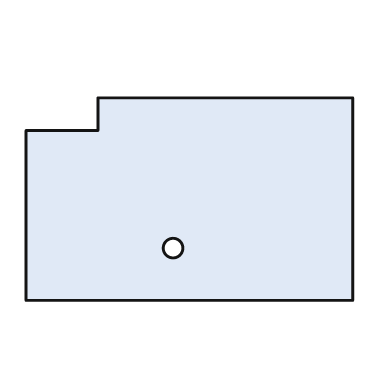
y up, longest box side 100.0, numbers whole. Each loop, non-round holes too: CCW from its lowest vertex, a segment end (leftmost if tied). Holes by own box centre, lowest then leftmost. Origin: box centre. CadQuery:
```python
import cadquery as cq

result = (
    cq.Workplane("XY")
    .moveTo(-50.0, -31.0)
    .lineTo(50.0, -31.0)
    .lineTo(50.0, 31.0)
    .lineTo(-28.0, 31.0)
    .lineTo(-28.0, 21.0)
    .lineTo(-50.0, 21.0)
    .close()
    .moveTo(-5.0, -15.0)
    .circle(3.0)
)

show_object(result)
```